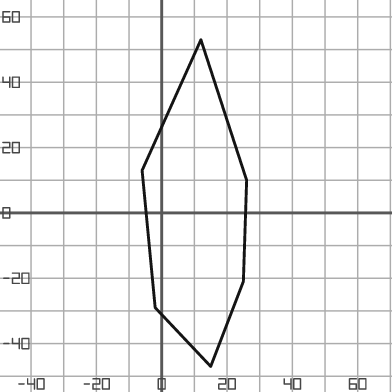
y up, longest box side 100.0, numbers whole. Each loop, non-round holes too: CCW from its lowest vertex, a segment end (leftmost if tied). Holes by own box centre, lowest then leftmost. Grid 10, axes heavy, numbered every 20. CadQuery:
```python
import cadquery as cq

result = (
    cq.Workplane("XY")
    .moveTo(15.0, -47.0)
    .lineTo(25.0, -21.0)
    .lineTo(26.0, 10.0)
    .lineTo(12.0, 53.0)
    .lineTo(-6.0, 13.0)
    .lineTo(-2.0, -29.0)
    .close()
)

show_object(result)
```